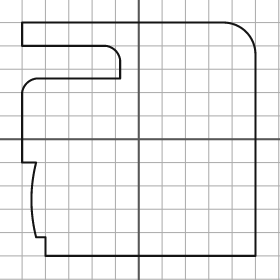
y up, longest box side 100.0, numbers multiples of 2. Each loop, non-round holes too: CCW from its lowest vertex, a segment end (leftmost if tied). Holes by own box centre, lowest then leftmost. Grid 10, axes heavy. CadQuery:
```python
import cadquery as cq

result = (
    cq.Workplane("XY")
    .moveTo(-40.0, -50.0)
    .lineTo(50.0, -50.0)
    .lineTo(50.0, 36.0)
    .threePointArc((46.0, 46.0), (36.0, 50.0))
    .lineTo(-50.0, 50.0)
    .lineTo(-50.0, 40.0)
    .lineTo(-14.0, 40.0)
    .threePointArc((-10.0, 38.0), (-8.0, 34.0))
    .lineTo(-8.0, 26.0)
    .lineTo(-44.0, 26.0)
    .threePointArc((-48.0, 24.0), (-50.0, 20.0))
    .lineTo(-50.0, -10.0)
    .lineTo(-44.0, -10.0)
    .threePointArc((-46.0, -26.0), (-44.0, -42.0))
    .lineTo(-40.0, -42.0)
    .close()
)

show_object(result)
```